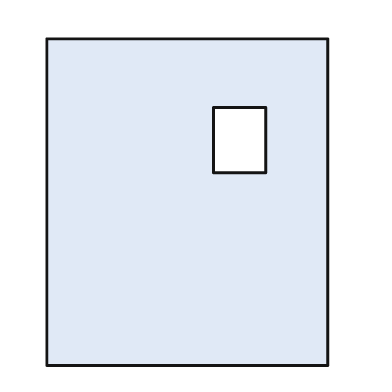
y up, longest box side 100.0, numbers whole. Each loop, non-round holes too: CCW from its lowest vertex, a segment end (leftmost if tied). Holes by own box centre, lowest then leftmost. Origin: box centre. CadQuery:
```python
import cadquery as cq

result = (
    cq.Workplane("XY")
    .moveTo(-43.0, -50.0)
    .lineTo(43.0, -50.0)
    .lineTo(43.0, 50.0)
    .lineTo(-43.0, 50.0)
    .close()
    .moveTo(8.0, 9.0)
    .lineTo(24.0, 9.0)
    .lineTo(24.0, 29.0)
    .lineTo(8.0, 29.0)
    .close()
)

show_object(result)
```